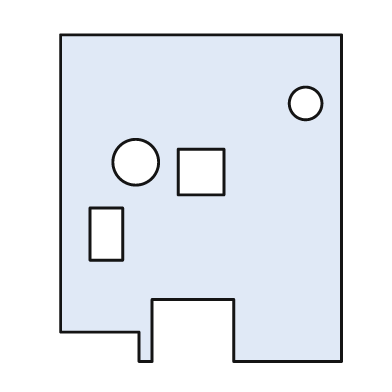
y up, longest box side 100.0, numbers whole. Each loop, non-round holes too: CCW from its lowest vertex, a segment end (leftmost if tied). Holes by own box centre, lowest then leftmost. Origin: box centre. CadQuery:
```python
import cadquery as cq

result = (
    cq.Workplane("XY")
    .moveTo(-19.0, -50.0)
    .lineTo(-15.0, -50.0)
    .lineTo(-15.0, -31.0)
    .lineTo(10.0, -31.0)
    .lineTo(10.0, -50.0)
    .lineTo(43.0, -50.0)
    .lineTo(43.0, 50.0)
    .lineTo(-43.0, 50.0)
    .lineTo(-43.0, -41.0)
    .lineTo(-19.0, -41.0)
    .close()
    .moveTo(-34.0, -19.0)
    .lineTo(-24.0, -19.0)
    .lineTo(-24.0, -3.0)
    .lineTo(-34.0, -3.0)
    .close()
    .moveTo(-7.0, 1.0)
    .lineTo(7.0, 1.0)
    .lineTo(7.0, 15.0)
    .lineTo(-7.0, 15.0)
    .close()
    .moveTo(-20.0, 11.0)
    .circle(7.0)
    .moveTo(32.0, 29.0)
    .circle(5.0)
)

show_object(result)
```